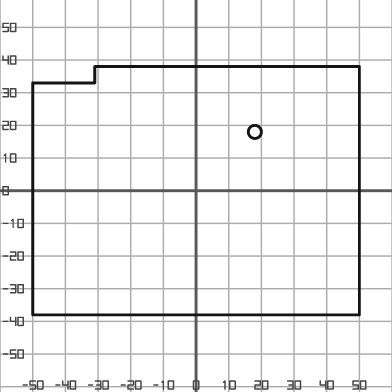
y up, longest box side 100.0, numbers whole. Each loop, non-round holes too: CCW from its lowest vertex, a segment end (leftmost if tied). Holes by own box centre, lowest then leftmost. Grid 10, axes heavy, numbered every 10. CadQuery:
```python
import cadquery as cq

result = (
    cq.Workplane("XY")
    .moveTo(-50.0, -38.0)
    .lineTo(50.0, -38.0)
    .lineTo(50.0, 38.0)
    .lineTo(-31.0, 38.0)
    .lineTo(-31.0, 33.0)
    .lineTo(-50.0, 33.0)
    .close()
    .moveTo(18.0, 18.0)
    .circle(2.0)
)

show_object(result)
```